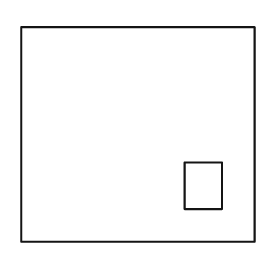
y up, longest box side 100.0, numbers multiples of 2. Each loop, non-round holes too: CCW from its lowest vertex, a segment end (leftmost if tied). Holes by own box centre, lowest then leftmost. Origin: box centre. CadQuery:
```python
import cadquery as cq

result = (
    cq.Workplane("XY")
    .moveTo(-50.0, -46.0)
    .lineTo(50.0, -46.0)
    .lineTo(50.0, 46.0)
    .lineTo(-50.0, 46.0)
    .close()
    .moveTo(20.0, -32.0)
    .lineTo(36.0, -32.0)
    .lineTo(36.0, -12.0)
    .lineTo(20.0, -12.0)
    .close()
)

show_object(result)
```